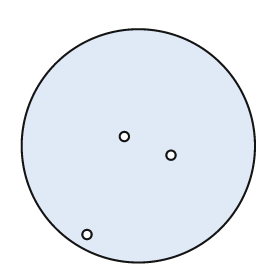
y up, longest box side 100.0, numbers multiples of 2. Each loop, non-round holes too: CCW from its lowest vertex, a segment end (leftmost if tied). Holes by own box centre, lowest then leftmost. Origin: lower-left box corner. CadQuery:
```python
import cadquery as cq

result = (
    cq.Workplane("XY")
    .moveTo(50.0, 50.0)
    .circle(50.0)
    .moveTo(28.0, 12.0)
    .circle(2.0)
    .moveTo(64.0, 46.0)
    .circle(2.0)
    .moveTo(44.0, 54.0)
    .circle(2.0)
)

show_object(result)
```